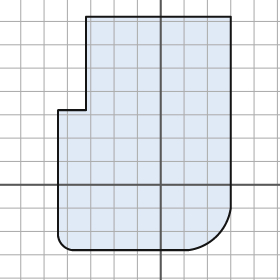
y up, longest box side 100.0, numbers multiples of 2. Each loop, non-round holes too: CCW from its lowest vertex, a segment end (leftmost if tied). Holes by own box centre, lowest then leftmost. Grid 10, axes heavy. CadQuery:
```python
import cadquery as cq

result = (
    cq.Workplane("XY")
    .moveTo(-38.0, -28.0)
    .lineTo(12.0, -28.0)
    .threePointArc((24.0, -22.0), (30.0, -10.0))
    .lineTo(30.0, 72.0)
    .lineTo(-32.0, 72.0)
    .lineTo(-32.0, 32.0)
    .lineTo(-44.0, 32.0)
    .lineTo(-44.0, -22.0)
    .threePointArc((-42.0, -26.0), (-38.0, -28.0))
    .close()
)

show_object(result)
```